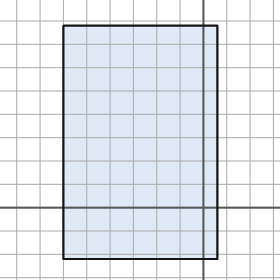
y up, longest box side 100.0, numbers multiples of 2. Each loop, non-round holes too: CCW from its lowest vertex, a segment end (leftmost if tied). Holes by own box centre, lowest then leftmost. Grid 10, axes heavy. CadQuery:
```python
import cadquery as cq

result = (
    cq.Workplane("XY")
    .moveTo(-60.0, -22.0)
    .lineTo(6.0, -22.0)
    .lineTo(6.0, 78.0)
    .lineTo(-60.0, 78.0)
    .close()
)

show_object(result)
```